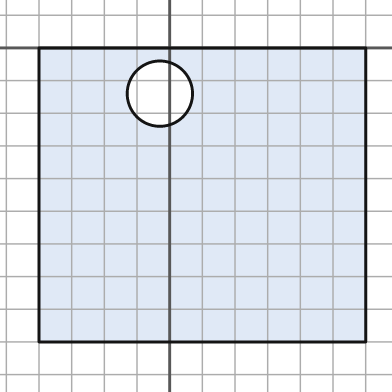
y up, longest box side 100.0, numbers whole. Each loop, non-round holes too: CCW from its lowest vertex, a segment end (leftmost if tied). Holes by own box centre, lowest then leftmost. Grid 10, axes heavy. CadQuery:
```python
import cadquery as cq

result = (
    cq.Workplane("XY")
    .moveTo(-40.0, -90.0)
    .lineTo(60.0, -90.0)
    .lineTo(60.0, 0.0)
    .lineTo(-40.0, 0.0)
    .close()
    .moveTo(-3.0, -14.0)
    .circle(10.0)
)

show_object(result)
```